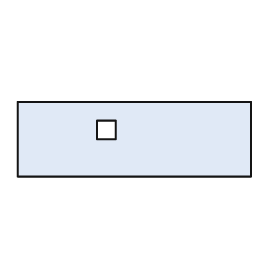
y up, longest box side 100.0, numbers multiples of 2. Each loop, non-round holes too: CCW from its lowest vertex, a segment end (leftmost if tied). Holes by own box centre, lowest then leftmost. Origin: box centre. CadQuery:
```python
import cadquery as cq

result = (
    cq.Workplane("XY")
    .moveTo(-50.0, -16.0)
    .lineTo(50.0, -16.0)
    .lineTo(50.0, 16.0)
    .lineTo(-50.0, 16.0)
    .close()
    .moveTo(-16.0, 0.0)
    .lineTo(-8.0, 0.0)
    .lineTo(-8.0, 8.0)
    .lineTo(-16.0, 8.0)
    .close()
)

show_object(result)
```